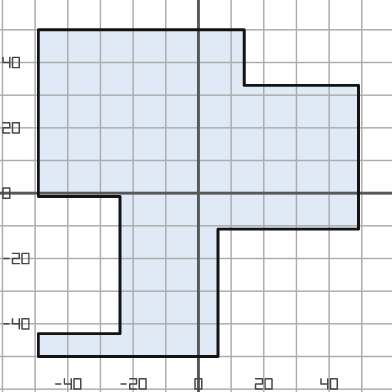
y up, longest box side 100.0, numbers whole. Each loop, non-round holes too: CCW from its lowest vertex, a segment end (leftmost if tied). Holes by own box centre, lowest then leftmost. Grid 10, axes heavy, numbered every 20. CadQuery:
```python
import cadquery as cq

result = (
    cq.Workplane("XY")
    .moveTo(-49.0, -50.0)
    .lineTo(6.0, -50.0)
    .lineTo(6.0, -11.0)
    .lineTo(49.0, -11.0)
    .lineTo(49.0, 33.0)
    .lineTo(14.0, 33.0)
    .lineTo(14.0, 50.0)
    .lineTo(-49.0, 50.0)
    .lineTo(-49.0, -1.0)
    .lineTo(-24.0, -1.0)
    .lineTo(-24.0, -43.0)
    .lineTo(-49.0, -43.0)
    .close()
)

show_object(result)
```